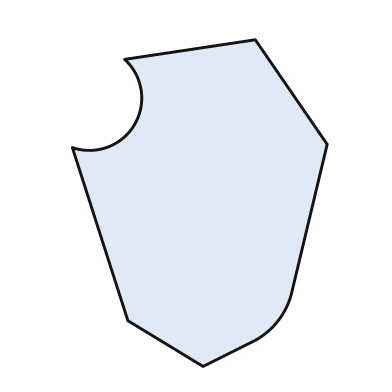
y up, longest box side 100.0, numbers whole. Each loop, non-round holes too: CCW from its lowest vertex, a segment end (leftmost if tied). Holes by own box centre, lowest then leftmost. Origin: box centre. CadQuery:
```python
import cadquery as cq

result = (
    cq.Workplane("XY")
    .moveTo(1.0, -50.0)
    .lineTo(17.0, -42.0)
    .threePointArc((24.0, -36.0), (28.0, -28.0))
    .lineTo(39.0, 18.0)
    .lineTo(17.0, 50.0)
    .lineTo(-23.0, 44.0)
    .threePointArc((-20.0, 24.0), (-39.0, 17.0))
    .lineTo(-22.0, -36.0)
    .close()
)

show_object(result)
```